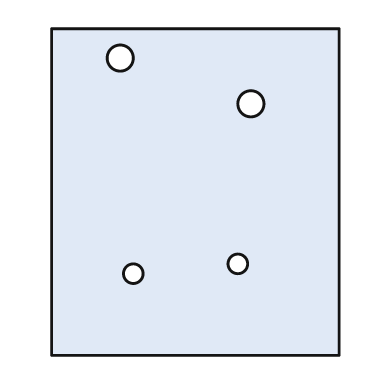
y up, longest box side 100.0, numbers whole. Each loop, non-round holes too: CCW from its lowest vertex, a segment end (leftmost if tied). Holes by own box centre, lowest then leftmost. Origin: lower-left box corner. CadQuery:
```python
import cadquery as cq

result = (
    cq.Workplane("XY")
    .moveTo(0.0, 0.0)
    .lineTo(88.0, 0.0)
    .lineTo(88.0, 100.0)
    .lineTo(0.0, 100.0)
    .close()
    .moveTo(25.0, 25.0)
    .circle(3.0)
    .moveTo(57.0, 28.0)
    .circle(3.0)
    .moveTo(61.0, 77.0)
    .circle(4.0)
    .moveTo(21.0, 91.0)
    .circle(4.0)
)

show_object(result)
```